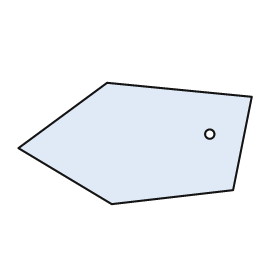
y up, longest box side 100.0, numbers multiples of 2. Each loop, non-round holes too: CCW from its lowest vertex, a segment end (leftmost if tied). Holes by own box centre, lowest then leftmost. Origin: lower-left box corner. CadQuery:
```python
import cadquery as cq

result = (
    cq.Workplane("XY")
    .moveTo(40.0, 0.0)
    .lineTo(92.0, 6.0)
    .lineTo(100.0, 46.0)
    .lineTo(38.0, 52.0)
    .lineTo(0.0, 24.0)
    .close()
    .moveTo(82.0, 30.0)
    .circle(2.0)
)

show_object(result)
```